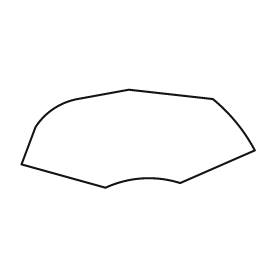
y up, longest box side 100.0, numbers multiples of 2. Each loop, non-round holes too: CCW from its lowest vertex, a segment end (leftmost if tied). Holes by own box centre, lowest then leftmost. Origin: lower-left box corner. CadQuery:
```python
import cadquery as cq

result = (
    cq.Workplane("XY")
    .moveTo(36.0, 0.0)
    .threePointArc((52.0, 4.0), (68.0, 2.0))
    .lineTo(100.0, 16.0)
    .threePointArc((92.0, 28.0), (82.0, 38.0))
    .lineTo(46.0, 42.0)
    .lineTo(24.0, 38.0)
    .threePointArc((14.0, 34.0), (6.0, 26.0))
    .lineTo(0.0, 10.0)
    .close()
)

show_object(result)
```